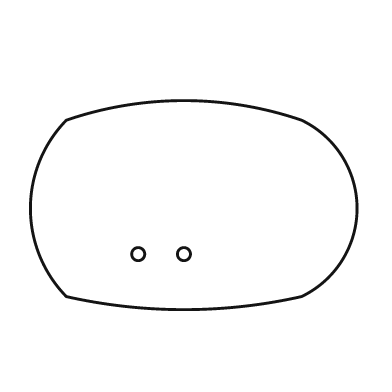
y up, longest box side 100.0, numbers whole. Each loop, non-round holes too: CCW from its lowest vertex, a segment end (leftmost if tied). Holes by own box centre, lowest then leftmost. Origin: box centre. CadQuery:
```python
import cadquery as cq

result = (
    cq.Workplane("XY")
    .moveTo(-39.0, -28.0)
    .threePointArc((-3.0, -32.0), (33.0, -28.0))
    .threePointArc((50.0, -1.0), (33.0, 26.0))
    .threePointArc((-3.0, 32.0), (-39.0, 26.0))
    .threePointArc((-50.0, -1.0), (-39.0, -28.0))
    .close()
    .moveTo(-17.0, -15.0)
    .circle(2.0)
    .moveTo(-3.0, -15.0)
    .circle(2.0)
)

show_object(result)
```